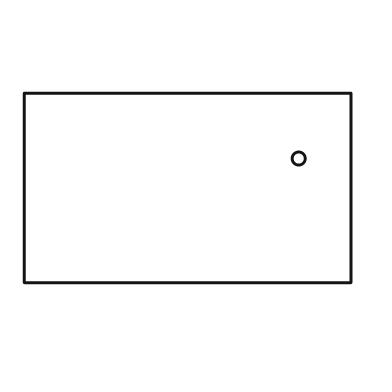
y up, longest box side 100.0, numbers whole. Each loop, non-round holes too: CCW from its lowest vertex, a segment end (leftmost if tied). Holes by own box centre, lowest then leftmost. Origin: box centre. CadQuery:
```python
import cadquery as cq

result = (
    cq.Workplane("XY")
    .moveTo(-50.0, -29.0)
    .lineTo(50.0, -29.0)
    .lineTo(50.0, 29.0)
    .lineTo(-50.0, 29.0)
    .close()
    .moveTo(34.0, 9.0)
    .circle(2.0)
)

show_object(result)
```